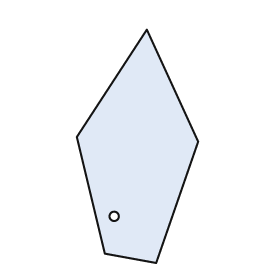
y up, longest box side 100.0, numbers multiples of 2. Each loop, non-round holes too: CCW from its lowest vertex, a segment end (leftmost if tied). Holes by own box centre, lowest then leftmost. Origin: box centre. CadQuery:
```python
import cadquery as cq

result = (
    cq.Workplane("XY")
    .moveTo(8.0, -50.0)
    .lineTo(26.0, 2.0)
    .lineTo(4.0, 50.0)
    .lineTo(-26.0, 4.0)
    .lineTo(-14.0, -46.0)
    .close()
    .moveTo(-10.0, -30.0)
    .circle(2.0)
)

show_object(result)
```